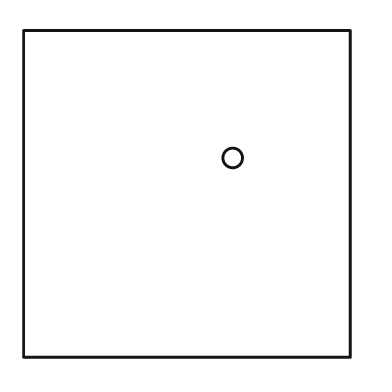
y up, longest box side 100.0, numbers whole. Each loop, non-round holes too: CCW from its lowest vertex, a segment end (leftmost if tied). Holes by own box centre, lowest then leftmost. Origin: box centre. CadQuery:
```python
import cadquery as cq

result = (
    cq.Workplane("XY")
    .moveTo(-50.0, -50.0)
    .lineTo(50.0, -50.0)
    .lineTo(50.0, 50.0)
    .lineTo(-50.0, 50.0)
    .close()
    .moveTo(14.0, 11.0)
    .circle(3.0)
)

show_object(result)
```